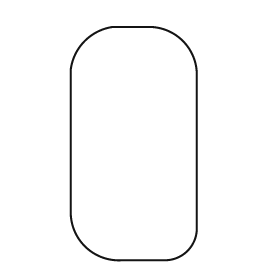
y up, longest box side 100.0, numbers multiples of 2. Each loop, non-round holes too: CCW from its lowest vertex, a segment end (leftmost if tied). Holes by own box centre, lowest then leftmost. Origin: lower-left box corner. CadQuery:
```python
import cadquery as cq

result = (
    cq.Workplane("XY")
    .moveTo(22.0, 0.0)
    .lineTo(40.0, 0.0)
    .threePointArc((50.0, 4.0), (54.0, 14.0))
    .lineTo(54.0, 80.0)
    .threePointArc((48.0, 94.0), (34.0, 100.0))
    .lineTo(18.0, 100.0)
    .threePointArc((6.0, 94.0), (0.0, 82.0))
    .lineTo(0.0, 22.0)
    .threePointArc((6.0, 6.0), (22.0, 0.0))
    .close()
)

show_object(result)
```